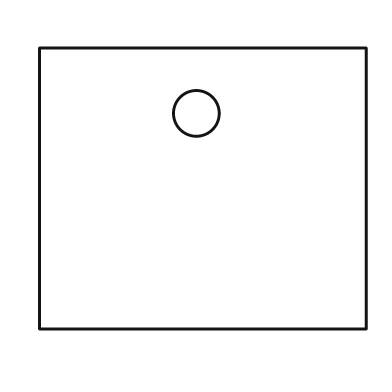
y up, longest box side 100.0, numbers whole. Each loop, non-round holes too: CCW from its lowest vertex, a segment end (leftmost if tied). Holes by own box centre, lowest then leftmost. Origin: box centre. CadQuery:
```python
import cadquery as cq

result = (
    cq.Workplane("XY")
    .moveTo(-50.0, -43.0)
    .lineTo(50.0, -43.0)
    .lineTo(50.0, 43.0)
    .lineTo(-50.0, 43.0)
    .close()
    .moveTo(-2.0, 23.0)
    .circle(7.0)
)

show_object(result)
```